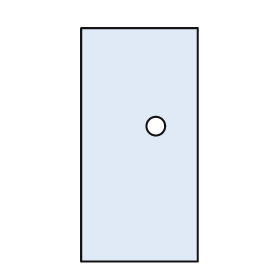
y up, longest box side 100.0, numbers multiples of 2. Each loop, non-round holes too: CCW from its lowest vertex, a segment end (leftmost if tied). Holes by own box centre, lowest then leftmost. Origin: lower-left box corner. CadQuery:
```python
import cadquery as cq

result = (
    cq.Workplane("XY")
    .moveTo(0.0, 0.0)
    .lineTo(50.0, 0.0)
    .lineTo(50.0, 100.0)
    .lineTo(0.0, 100.0)
    .close()
    .moveTo(32.0, 58.0)
    .circle(4.0)
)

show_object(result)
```